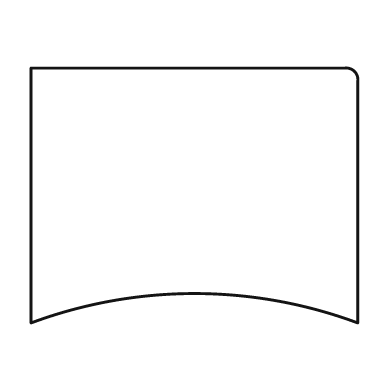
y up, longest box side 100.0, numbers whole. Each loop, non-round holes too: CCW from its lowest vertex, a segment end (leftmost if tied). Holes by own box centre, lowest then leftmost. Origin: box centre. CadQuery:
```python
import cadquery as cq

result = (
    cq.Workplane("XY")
    .moveTo(-50.0, -39.0)
    .threePointArc((0.0, -30.0), (50.0, -39.0))
    .lineTo(50.0, 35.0)
    .threePointArc((49.0, 38.0), (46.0, 39.0))
    .lineTo(-50.0, 39.0)
    .close()
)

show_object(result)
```